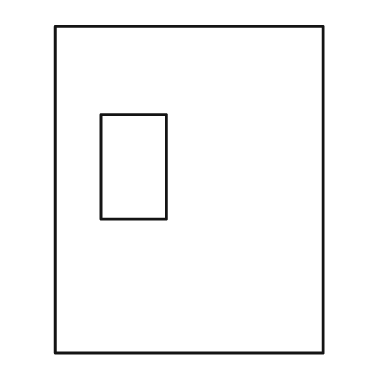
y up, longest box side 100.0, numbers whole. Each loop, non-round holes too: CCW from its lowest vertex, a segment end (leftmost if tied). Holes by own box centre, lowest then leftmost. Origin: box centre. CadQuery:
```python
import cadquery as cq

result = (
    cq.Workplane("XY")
    .moveTo(-41.0, -50.0)
    .lineTo(41.0, -50.0)
    .lineTo(41.0, 50.0)
    .lineTo(-41.0, 50.0)
    .close()
    .moveTo(-27.0, -9.0)
    .lineTo(-7.0, -9.0)
    .lineTo(-7.0, 23.0)
    .lineTo(-27.0, 23.0)
    .close()
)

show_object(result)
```